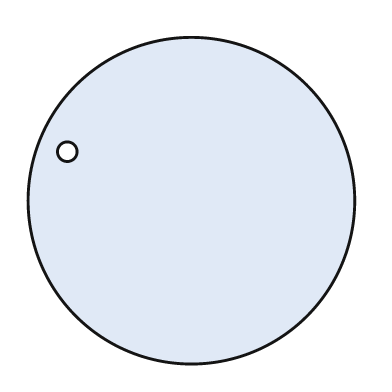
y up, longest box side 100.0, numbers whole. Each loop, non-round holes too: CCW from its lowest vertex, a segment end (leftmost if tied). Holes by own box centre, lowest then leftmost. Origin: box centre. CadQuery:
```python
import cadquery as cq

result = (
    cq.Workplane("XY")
    .moveTo(0.0, 0.0)
    .circle(50.0)
    .moveTo(-38.0, 15.0)
    .circle(3.0)
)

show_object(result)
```